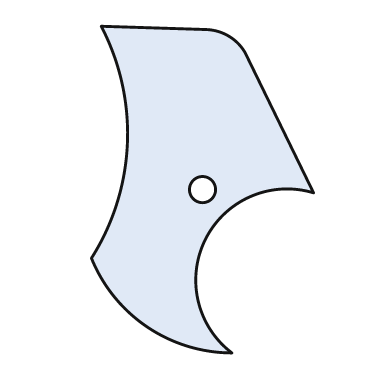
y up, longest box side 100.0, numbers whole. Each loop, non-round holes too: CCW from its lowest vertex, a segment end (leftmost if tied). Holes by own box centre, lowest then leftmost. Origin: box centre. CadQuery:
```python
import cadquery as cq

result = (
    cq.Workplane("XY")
    .moveTo(9.0, -50.0)
    .threePointArc((1.0, -15.0), (34.0, -1.0))
    .lineTo(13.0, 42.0)
    .threePointArc((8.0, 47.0), (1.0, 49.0))
    .lineTo(-31.0, 50.0)
    .threePointArc((-23.0, 14.0), (-34.0, -21.0))
    .threePointArc((-17.0, -42.0), (9.0, -50.0))
    .close()
    .moveTo(0.0, 0.0)
    .circle(4.0)
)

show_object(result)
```